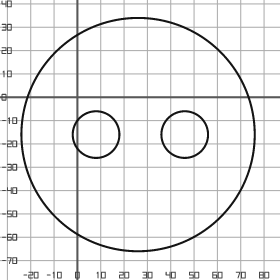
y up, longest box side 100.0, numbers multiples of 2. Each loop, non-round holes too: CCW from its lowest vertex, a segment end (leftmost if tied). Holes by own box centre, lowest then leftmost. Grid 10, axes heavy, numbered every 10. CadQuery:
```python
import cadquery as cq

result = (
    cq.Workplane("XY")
    .moveTo(26.0, -16.0)
    .circle(50.0)
    .moveTo(8.0, -16.0)
    .circle(10.0)
    .moveTo(46.0, -16.0)
    .circle(10.0)
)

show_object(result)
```